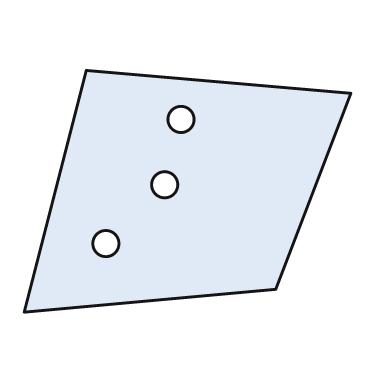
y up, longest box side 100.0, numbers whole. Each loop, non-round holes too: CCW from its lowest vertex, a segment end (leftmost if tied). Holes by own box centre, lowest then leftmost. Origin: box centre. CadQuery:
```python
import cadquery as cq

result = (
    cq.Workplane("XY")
    .moveTo(-50.0, -37.0)
    .lineTo(27.0, -30.0)
    .lineTo(50.0, 30.0)
    .lineTo(-31.0, 37.0)
    .close()
    .moveTo(-25.0, -16.0)
    .circle(4.0)
    .moveTo(-7.0, 2.0)
    .circle(4.0)
    .moveTo(-2.0, 22.0)
    .circle(4.0)
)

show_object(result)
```